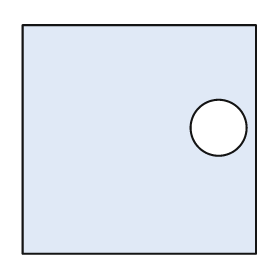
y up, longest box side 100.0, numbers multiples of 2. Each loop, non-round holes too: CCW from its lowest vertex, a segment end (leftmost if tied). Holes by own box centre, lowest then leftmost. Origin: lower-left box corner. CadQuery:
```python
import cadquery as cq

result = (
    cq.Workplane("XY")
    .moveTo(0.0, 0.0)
    .lineTo(100.0, 0.0)
    .lineTo(100.0, 98.0)
    .lineTo(0.0, 98.0)
    .close()
    .moveTo(84.0, 54.0)
    .circle(12.0)
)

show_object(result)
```